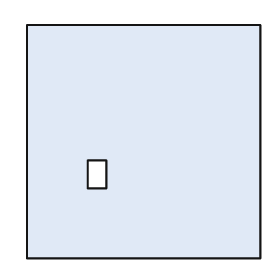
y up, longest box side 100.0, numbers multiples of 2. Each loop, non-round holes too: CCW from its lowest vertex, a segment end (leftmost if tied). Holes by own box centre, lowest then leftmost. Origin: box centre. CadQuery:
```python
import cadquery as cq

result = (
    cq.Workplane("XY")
    .moveTo(-50.0, -50.0)
    .lineTo(50.0, -50.0)
    .lineTo(50.0, 50.0)
    .lineTo(-50.0, 50.0)
    .close()
    .moveTo(-24.0, -20.0)
    .lineTo(-16.0, -20.0)
    .lineTo(-16.0, -8.0)
    .lineTo(-24.0, -8.0)
    .close()
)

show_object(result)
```